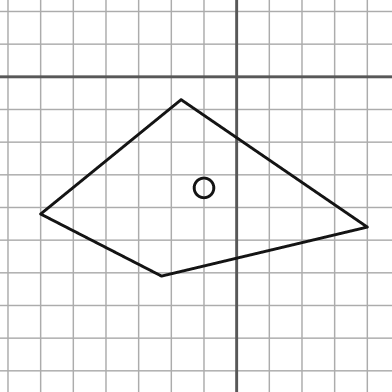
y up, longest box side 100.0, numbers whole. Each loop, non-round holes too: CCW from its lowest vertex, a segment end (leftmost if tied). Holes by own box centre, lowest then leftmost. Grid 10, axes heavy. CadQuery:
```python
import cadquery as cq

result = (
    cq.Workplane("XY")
    .moveTo(-23.0, -61.0)
    .lineTo(40.0, -46.0)
    .lineTo(-17.0, -7.0)
    .lineTo(-60.0, -42.0)
    .close()
    .moveTo(-10.0, -34.0)
    .circle(3.0)
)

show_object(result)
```